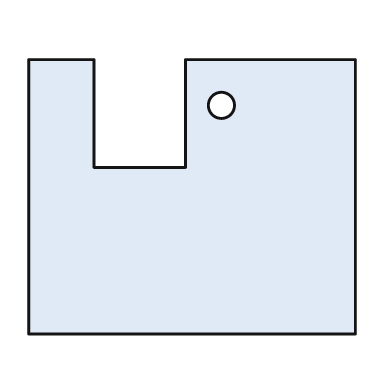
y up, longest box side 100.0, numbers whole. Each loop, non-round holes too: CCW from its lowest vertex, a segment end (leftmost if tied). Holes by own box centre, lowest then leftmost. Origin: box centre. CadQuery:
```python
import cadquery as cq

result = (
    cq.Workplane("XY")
    .moveTo(-50.0, -42.0)
    .lineTo(50.0, -42.0)
    .lineTo(50.0, 42.0)
    .lineTo(-2.0, 42.0)
    .lineTo(-2.0, 9.0)
    .lineTo(-30.0, 9.0)
    .lineTo(-30.0, 42.0)
    .lineTo(-50.0, 42.0)
    .close()
    .moveTo(9.0, 28.0)
    .circle(4.0)
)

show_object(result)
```